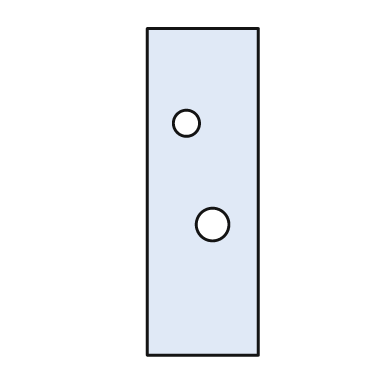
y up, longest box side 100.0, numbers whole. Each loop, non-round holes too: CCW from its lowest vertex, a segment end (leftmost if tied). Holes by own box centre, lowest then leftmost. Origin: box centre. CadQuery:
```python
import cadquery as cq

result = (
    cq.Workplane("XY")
    .moveTo(-17.0, -50.0)
    .lineTo(17.0, -50.0)
    .lineTo(17.0, 50.0)
    .lineTo(-17.0, 50.0)
    .close()
    .moveTo(3.0, -10.0)
    .circle(5.0)
    .moveTo(-5.0, 21.0)
    .circle(4.0)
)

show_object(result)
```